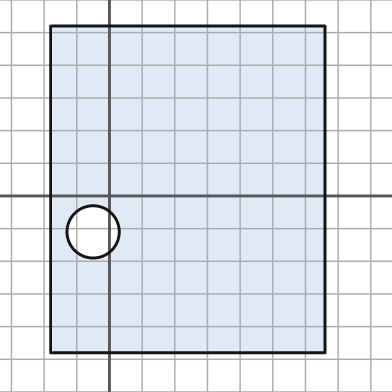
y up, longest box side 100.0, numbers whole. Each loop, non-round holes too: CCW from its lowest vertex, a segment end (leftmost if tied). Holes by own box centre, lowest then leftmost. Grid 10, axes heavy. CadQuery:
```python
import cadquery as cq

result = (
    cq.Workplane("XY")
    .moveTo(-18.0, -48.0)
    .lineTo(66.0, -48.0)
    .lineTo(66.0, 52.0)
    .lineTo(-18.0, 52.0)
    .close()
    .moveTo(-5.0, -11.0)
    .circle(8.0)
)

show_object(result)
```